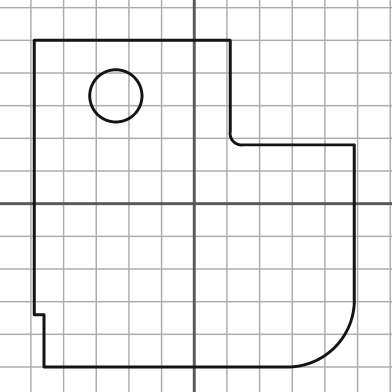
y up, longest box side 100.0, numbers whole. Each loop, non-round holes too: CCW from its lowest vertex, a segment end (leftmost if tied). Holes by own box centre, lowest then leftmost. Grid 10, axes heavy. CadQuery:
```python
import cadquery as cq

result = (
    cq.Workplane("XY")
    .moveTo(-46.0, -50.0)
    .lineTo(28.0, -50.0)
    .threePointArc((43.0, -44.0), (49.0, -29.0))
    .lineTo(49.0, 18.0)
    .lineTo(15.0, 18.0)
    .threePointArc((12.0, 19.0), (11.0, 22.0))
    .lineTo(11.0, 50.0)
    .lineTo(-49.0, 50.0)
    .lineTo(-49.0, -34.0)
    .lineTo(-46.0, -34.0)
    .close()
    .moveTo(-24.0, 33.0)
    .circle(8.0)
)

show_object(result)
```